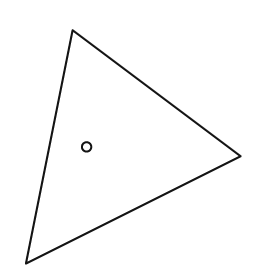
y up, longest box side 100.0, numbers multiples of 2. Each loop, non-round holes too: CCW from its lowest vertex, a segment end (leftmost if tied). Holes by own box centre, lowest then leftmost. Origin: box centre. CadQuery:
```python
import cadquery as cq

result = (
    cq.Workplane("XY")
    .moveTo(-46.0, -50.0)
    .lineTo(46.0, -4.0)
    .lineTo(-26.0, 50.0)
    .close()
    .moveTo(-20.0, 0.0)
    .circle(2.0)
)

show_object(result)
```